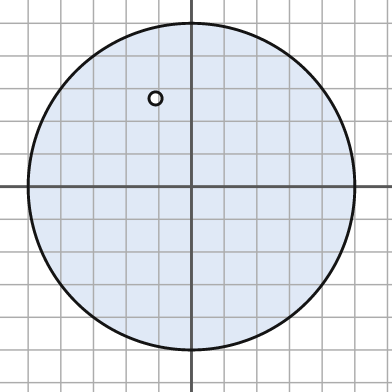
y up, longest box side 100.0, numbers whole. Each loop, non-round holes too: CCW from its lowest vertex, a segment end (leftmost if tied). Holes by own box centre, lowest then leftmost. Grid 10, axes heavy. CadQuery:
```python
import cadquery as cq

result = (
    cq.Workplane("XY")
    .moveTo(0.0, 0.0)
    .circle(50.0)
    .moveTo(-11.0, 27.0)
    .circle(2.0)
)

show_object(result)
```